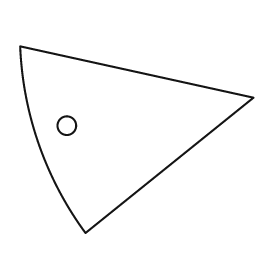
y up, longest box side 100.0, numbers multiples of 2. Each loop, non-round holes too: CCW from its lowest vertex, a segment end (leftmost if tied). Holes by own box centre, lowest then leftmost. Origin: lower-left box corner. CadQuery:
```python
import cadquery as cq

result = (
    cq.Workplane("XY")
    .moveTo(28.0, 0.0)
    .lineTo(100.0, 58.0)
    .lineTo(0.0, 80.0)
    .threePointArc((8.0, 38.0), (28.0, 0.0))
    .close()
    .moveTo(20.0, 46.0)
    .circle(4.0)
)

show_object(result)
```